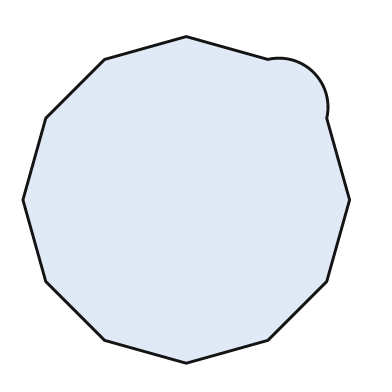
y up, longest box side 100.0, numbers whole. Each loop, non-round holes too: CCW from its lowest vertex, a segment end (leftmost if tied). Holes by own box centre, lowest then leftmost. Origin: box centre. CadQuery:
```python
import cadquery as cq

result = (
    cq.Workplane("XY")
    .moveTo(0.0, -50.0)
    .lineTo(25.0, -43.0)
    .lineTo(43.0, -25.0)
    .lineTo(50.0, 0.0)
    .lineTo(43.0, 25.0)
    .threePointArc((39.0, 39.0), (25.0, 43.0))
    .lineTo(0.0, 50.0)
    .lineTo(-25.0, 43.0)
    .lineTo(-43.0, 25.0)
    .lineTo(-50.0, 0.0)
    .lineTo(-43.0, -25.0)
    .lineTo(-25.0, -43.0)
    .close()
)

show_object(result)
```